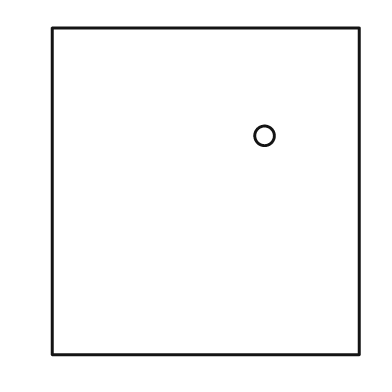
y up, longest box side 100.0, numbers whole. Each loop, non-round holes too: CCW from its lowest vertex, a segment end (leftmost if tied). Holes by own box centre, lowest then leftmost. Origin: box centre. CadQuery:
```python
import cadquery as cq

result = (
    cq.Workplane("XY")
    .moveTo(-47.0, -50.0)
    .lineTo(47.0, -50.0)
    .lineTo(47.0, 50.0)
    .lineTo(-47.0, 50.0)
    .close()
    .moveTo(18.0, 17.0)
    .circle(3.0)
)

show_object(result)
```